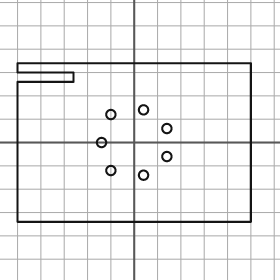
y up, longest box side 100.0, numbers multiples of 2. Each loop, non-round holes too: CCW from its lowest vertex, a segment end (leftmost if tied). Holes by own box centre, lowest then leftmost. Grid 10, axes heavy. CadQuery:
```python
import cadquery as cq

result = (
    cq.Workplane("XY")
    .moveTo(-50.0, -34.0)
    .lineTo(50.0, -34.0)
    .lineTo(50.0, 34.0)
    .lineTo(-50.0, 34.0)
    .lineTo(-50.0, 30.0)
    .lineTo(-26.0, 30.0)
    .lineTo(-26.0, 26.0)
    .lineTo(-50.0, 26.0)
    .close()
    .moveTo(4.0, -14.0)
    .circle(2.0)
    .moveTo(-10.0, -12.0)
    .circle(2.0)
    .moveTo(14.0, -6.0)
    .circle(2.0)
    .moveTo(-14.0, 0.0)
    .circle(2.0)
    .moveTo(14.0, 6.0)
    .circle(2.0)
    .moveTo(-10.0, 12.0)
    .circle(2.0)
    .moveTo(4.0, 14.0)
    .circle(2.0)
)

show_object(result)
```